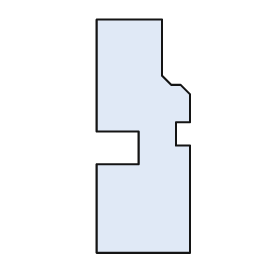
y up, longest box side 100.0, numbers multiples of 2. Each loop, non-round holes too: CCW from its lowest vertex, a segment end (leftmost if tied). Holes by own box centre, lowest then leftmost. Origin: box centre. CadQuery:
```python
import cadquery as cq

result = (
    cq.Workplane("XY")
    .moveTo(-20.0, -50.0)
    .lineTo(20.0, -50.0)
    .lineTo(20.0, -4.0)
    .lineTo(14.0, -4.0)
    .lineTo(14.0, 6.0)
    .lineTo(20.0, 6.0)
    .lineTo(20.0, 18.0)
    .lineTo(16.0, 22.0)
    .lineTo(12.0, 22.0)
    .lineTo(8.0, 26.0)
    .lineTo(8.0, 50.0)
    .lineTo(-20.0, 50.0)
    .lineTo(-20.0, 2.0)
    .lineTo(-2.0, 2.0)
    .lineTo(-2.0, -12.0)
    .lineTo(-20.0, -12.0)
    .close()
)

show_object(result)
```